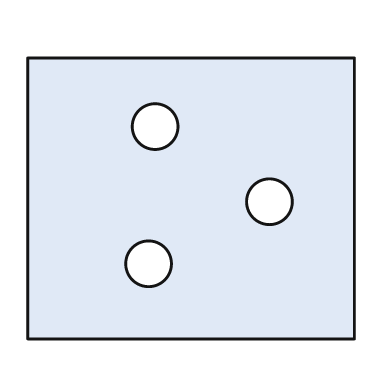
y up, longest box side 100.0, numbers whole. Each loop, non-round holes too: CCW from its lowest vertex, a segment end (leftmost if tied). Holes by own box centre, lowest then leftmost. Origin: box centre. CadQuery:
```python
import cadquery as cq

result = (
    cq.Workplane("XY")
    .moveTo(-50.0, -43.0)
    .lineTo(50.0, -43.0)
    .lineTo(50.0, 43.0)
    .lineTo(-50.0, 43.0)
    .close()
    .moveTo(-13.0, -20.0)
    .circle(7.0)
    .moveTo(24.0, -1.0)
    .circle(7.0)
    .moveTo(-11.0, 22.0)
    .circle(7.0)
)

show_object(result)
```